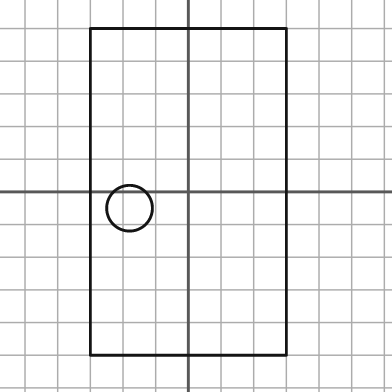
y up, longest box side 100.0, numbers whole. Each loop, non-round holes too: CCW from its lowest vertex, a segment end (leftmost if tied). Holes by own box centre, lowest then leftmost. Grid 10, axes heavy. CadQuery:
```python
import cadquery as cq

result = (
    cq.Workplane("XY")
    .moveTo(-30.0, -50.0)
    .lineTo(30.0, -50.0)
    .lineTo(30.0, 50.0)
    .lineTo(-30.0, 50.0)
    .close()
    .moveTo(-18.0, -5.0)
    .circle(7.0)
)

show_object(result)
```